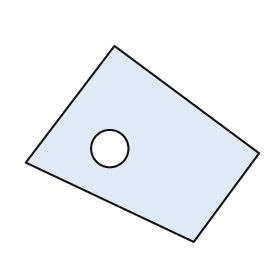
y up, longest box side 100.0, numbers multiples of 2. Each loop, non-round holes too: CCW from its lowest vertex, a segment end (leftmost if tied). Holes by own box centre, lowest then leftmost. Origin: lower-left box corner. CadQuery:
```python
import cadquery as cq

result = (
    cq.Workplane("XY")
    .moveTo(72.0, 0.0)
    .lineTo(100.0, 38.0)
    .lineTo(38.0, 84.0)
    .lineTo(0.0, 34.0)
    .close()
    .moveTo(36.0, 40.0)
    .circle(8.0)
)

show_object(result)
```